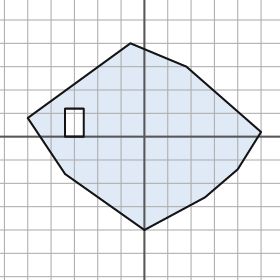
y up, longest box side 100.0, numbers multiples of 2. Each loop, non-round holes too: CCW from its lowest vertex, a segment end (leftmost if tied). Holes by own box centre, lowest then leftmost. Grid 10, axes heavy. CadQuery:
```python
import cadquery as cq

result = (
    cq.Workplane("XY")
    .moveTo(0.0, -40.0)
    .lineTo(26.0, -26.0)
    .lineTo(40.0, -14.0)
    .lineTo(50.0, 2.0)
    .lineTo(18.0, 30.0)
    .lineTo(-6.0, 40.0)
    .lineTo(-50.0, 8.0)
    .lineTo(-34.0, -16.0)
    .close()
    .moveTo(-34.0, 0.0)
    .lineTo(-26.0, 0.0)
    .lineTo(-26.0, 12.0)
    .lineTo(-34.0, 12.0)
    .close()
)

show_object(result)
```